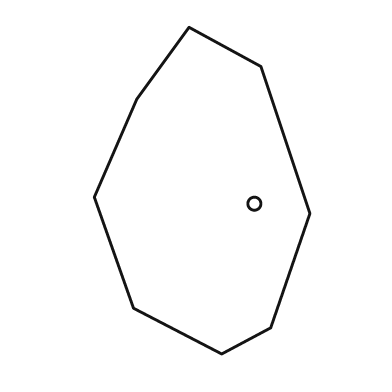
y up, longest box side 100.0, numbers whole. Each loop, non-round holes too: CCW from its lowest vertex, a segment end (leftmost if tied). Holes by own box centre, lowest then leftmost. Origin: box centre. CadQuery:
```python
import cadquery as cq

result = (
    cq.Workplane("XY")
    .moveTo(6.0, -50.0)
    .lineTo(21.0, -42.0)
    .lineTo(33.0, -7.0)
    .lineTo(18.0, 38.0)
    .lineTo(-4.0, 50.0)
    .lineTo(-20.0, 28.0)
    .lineTo(-33.0, -2.0)
    .lineTo(-21.0, -36.0)
    .close()
    .moveTo(16.0, -4.0)
    .circle(2.0)
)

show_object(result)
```